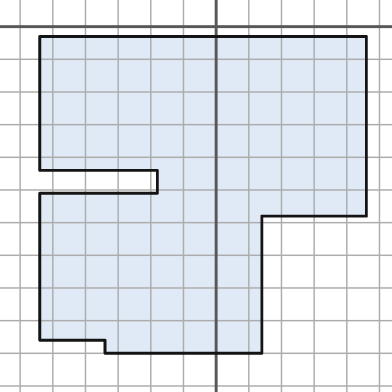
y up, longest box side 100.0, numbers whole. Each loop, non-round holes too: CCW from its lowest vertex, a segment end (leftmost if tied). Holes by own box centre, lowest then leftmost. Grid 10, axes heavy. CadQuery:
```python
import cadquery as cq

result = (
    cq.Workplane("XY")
    .moveTo(-34.0, -100.0)
    .lineTo(14.0, -100.0)
    .lineTo(14.0, -58.0)
    .lineTo(46.0, -58.0)
    .lineTo(46.0, -3.0)
    .lineTo(-54.0, -3.0)
    .lineTo(-54.0, -44.0)
    .lineTo(-18.0, -44.0)
    .lineTo(-18.0, -51.0)
    .lineTo(-54.0, -51.0)
    .lineTo(-54.0, -96.0)
    .lineTo(-34.0, -96.0)
    .close()
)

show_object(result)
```